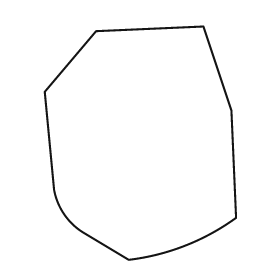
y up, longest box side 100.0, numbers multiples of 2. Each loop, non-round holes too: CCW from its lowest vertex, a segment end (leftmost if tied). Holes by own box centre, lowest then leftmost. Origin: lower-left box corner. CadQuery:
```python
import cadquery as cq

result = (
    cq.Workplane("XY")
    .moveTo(36.0, 0.0)
    .threePointArc((60.0, 6.0), (82.0, 18.0))
    .lineTo(80.0, 64.0)
    .lineTo(68.0, 100.0)
    .lineTo(22.0, 98.0)
    .lineTo(0.0, 72.0)
    .lineTo(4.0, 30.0)
    .threePointArc((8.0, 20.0), (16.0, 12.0))
    .close()
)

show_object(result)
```